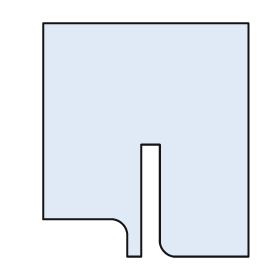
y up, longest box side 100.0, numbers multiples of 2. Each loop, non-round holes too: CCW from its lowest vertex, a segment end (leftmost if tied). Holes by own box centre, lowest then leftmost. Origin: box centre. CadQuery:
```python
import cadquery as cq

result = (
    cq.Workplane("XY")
    .moveTo(-8.0, -50.0)
    .lineTo(-2.0, -50.0)
    .lineTo(-2.0, -2.0)
    .lineTo(6.0, -2.0)
    .lineTo(6.0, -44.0)
    .threePointArc((8.0, -48.0), (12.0, -50.0))
    .lineTo(44.0, -50.0)
    .lineTo(44.0, 50.0)
    .lineTo(-44.0, 50.0)
    .lineTo(-44.0, -34.0)
    .lineTo(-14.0, -34.0)
    .threePointArc((-10.0, -36.0), (-8.0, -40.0))
    .close()
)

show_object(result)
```